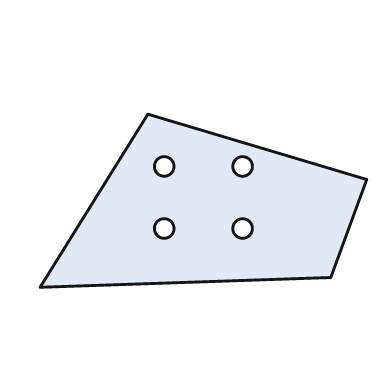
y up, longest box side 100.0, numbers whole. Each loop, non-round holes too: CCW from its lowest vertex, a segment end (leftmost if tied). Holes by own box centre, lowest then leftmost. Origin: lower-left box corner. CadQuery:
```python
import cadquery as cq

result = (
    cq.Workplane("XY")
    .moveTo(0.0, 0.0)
    .lineTo(89.0, 3.0)
    .lineTo(100.0, 33.0)
    .lineTo(33.0, 53.0)
    .close()
    .moveTo(38.0, 18.0)
    .circle(3.0)
    .moveTo(62.0, 18.0)
    .circle(3.0)
    .moveTo(38.0, 37.0)
    .circle(3.0)
    .moveTo(62.0, 37.0)
    .circle(3.0)
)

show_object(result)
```